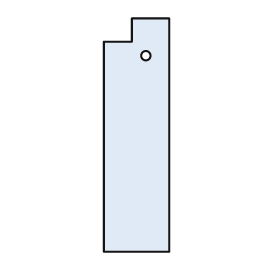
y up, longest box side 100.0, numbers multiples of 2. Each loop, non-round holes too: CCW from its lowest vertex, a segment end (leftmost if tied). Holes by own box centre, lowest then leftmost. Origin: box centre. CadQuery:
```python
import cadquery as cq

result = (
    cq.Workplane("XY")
    .moveTo(-14.0, -50.0)
    .lineTo(14.0, -50.0)
    .lineTo(14.0, 50.0)
    .lineTo(-2.0, 50.0)
    .lineTo(-2.0, 40.0)
    .lineTo(-14.0, 40.0)
    .close()
    .moveTo(4.0, 34.0)
    .circle(2.0)
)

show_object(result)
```